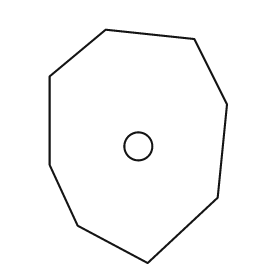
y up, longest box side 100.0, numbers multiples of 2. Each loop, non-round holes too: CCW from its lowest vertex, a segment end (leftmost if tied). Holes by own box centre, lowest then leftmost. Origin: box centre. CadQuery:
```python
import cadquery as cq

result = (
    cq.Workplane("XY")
    .moveTo(4.0, -50.0)
    .lineTo(34.0, -22.0)
    .lineTo(38.0, 18.0)
    .lineTo(24.0, 46.0)
    .lineTo(-14.0, 50.0)
    .lineTo(-38.0, 30.0)
    .lineTo(-38.0, -8.0)
    .lineTo(-26.0, -34.0)
    .close()
    .moveTo(0.0, 0.0)
    .circle(6.0)
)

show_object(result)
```